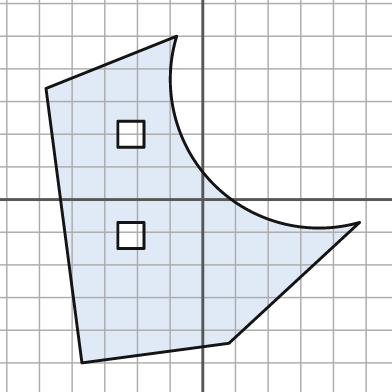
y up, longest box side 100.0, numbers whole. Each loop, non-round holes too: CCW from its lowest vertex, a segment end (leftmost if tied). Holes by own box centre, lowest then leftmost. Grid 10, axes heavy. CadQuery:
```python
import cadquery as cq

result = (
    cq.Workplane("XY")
    .moveTo(-37.0, -50.0)
    .lineTo(8.0, -44.0)
    .lineTo(48.0, -7.0)
    .threePointArc((3.0, 5.0), (-8.0, 50.0))
    .lineTo(-48.0, 34.0)
    .close()
    .moveTo(-26.0, -15.0)
    .lineTo(-18.0, -15.0)
    .lineTo(-18.0, -7.0)
    .lineTo(-26.0, -7.0)
    .close()
    .moveTo(-26.0, 16.0)
    .lineTo(-18.0, 16.0)
    .lineTo(-18.0, 24.0)
    .lineTo(-26.0, 24.0)
    .close()
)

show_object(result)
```